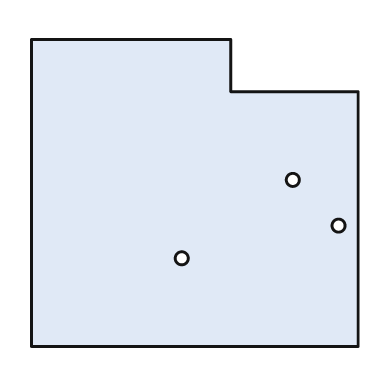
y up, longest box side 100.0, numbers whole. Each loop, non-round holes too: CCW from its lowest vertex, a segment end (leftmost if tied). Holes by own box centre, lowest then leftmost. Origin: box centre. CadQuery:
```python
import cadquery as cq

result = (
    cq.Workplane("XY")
    .moveTo(-50.0, -47.0)
    .lineTo(50.0, -47.0)
    .lineTo(50.0, 31.0)
    .lineTo(11.0, 31.0)
    .lineTo(11.0, 47.0)
    .lineTo(-50.0, 47.0)
    .close()
    .moveTo(-4.0, -20.0)
    .circle(2.0)
    .moveTo(44.0, -10.0)
    .circle(2.0)
    .moveTo(30.0, 4.0)
    .circle(2.0)
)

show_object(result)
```